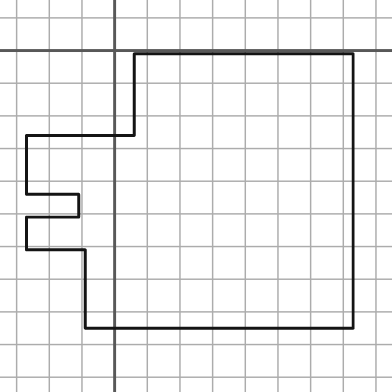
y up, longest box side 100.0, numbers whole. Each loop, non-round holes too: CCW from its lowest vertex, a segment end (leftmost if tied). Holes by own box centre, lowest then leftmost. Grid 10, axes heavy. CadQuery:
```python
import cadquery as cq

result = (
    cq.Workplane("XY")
    .moveTo(-9.0, -85.0)
    .lineTo(73.0, -85.0)
    .lineTo(73.0, -1.0)
    .lineTo(6.0, -1.0)
    .lineTo(6.0, -26.0)
    .lineTo(-27.0, -26.0)
    .lineTo(-27.0, -44.0)
    .lineTo(-11.0, -44.0)
    .lineTo(-11.0, -51.0)
    .lineTo(-27.0, -51.0)
    .lineTo(-27.0, -61.0)
    .lineTo(-9.0, -61.0)
    .close()
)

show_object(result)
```